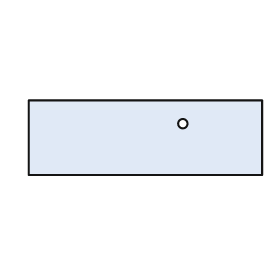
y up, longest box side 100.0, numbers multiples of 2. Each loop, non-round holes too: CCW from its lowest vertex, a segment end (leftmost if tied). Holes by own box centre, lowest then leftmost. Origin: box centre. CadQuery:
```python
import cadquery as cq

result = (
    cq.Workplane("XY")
    .moveTo(-50.0, -16.0)
    .lineTo(50.0, -16.0)
    .lineTo(50.0, 16.0)
    .lineTo(-50.0, 16.0)
    .close()
    .moveTo(16.0, 6.0)
    .circle(2.0)
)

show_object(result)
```